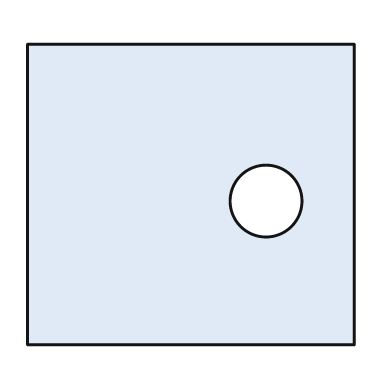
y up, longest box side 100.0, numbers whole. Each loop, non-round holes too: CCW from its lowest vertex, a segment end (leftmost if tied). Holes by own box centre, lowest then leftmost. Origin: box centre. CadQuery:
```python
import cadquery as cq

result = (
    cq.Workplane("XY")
    .moveTo(-50.0, -46.0)
    .lineTo(50.0, -46.0)
    .lineTo(50.0, 46.0)
    .lineTo(-50.0, 46.0)
    .close()
    .moveTo(23.0, -2.0)
    .circle(11.0)
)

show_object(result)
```